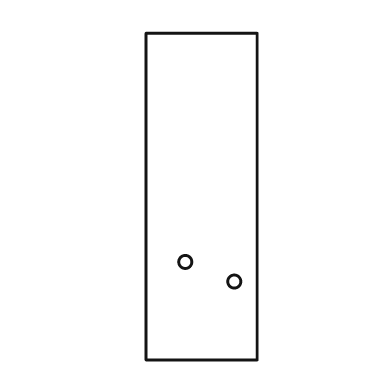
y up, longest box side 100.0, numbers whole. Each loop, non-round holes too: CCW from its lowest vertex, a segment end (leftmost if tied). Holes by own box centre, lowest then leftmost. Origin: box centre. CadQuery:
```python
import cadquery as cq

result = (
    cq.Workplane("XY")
    .moveTo(-17.0, -50.0)
    .lineTo(17.0, -50.0)
    .lineTo(17.0, 50.0)
    .lineTo(-17.0, 50.0)
    .close()
    .moveTo(10.0, -26.0)
    .circle(2.0)
    .moveTo(-5.0, -20.0)
    .circle(2.0)
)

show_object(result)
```